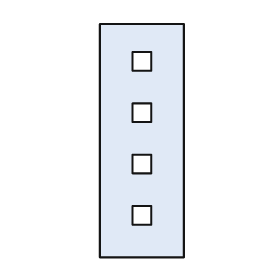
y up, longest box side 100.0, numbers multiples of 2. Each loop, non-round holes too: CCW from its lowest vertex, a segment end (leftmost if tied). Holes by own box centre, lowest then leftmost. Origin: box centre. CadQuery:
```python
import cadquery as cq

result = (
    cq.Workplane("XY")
    .moveTo(-18.0, -50.0)
    .lineTo(18.0, -50.0)
    .lineTo(18.0, 50.0)
    .lineTo(-18.0, 50.0)
    .close()
    .moveTo(-4.0, -36.0)
    .lineTo(4.0, -36.0)
    .lineTo(4.0, -28.0)
    .lineTo(-4.0, -28.0)
    .close()
    .moveTo(-4.0, -14.0)
    .lineTo(4.0, -14.0)
    .lineTo(4.0, -6.0)
    .lineTo(-4.0, -6.0)
    .close()
    .moveTo(-4.0, 8.0)
    .lineTo(4.0, 8.0)
    .lineTo(4.0, 16.0)
    .lineTo(-4.0, 16.0)
    .close()
    .moveTo(-4.0, 30.0)
    .lineTo(4.0, 30.0)
    .lineTo(4.0, 38.0)
    .lineTo(-4.0, 38.0)
    .close()
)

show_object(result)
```